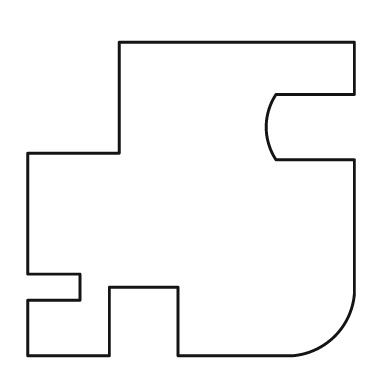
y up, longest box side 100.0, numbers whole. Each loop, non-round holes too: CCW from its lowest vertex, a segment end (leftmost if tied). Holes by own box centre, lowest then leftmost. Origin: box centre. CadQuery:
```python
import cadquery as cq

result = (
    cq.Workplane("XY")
    .moveTo(-50.0, -48.0)
    .lineTo(-25.0, -48.0)
    .lineTo(-25.0, -27.0)
    .lineTo(-4.0, -27.0)
    .lineTo(-4.0, -48.0)
    .lineTo(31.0, -48.0)
    .threePointArc((44.0, -42.0), (50.0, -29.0))
    .lineTo(50.0, 12.0)
    .lineTo(26.0, 12.0)
    .threePointArc((23.0, 22.0), (26.0, 32.0))
    .lineTo(50.0, 32.0)
    .lineTo(50.0, 48.0)
    .lineTo(-22.0, 48.0)
    .lineTo(-22.0, 14.0)
    .lineTo(-50.0, 14.0)
    .lineTo(-50.0, -23.0)
    .lineTo(-34.0, -23.0)
    .lineTo(-34.0, -31.0)
    .lineTo(-50.0, -31.0)
    .close()
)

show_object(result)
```